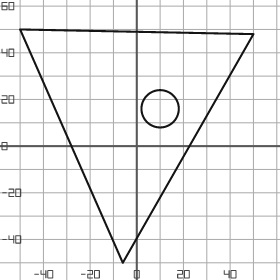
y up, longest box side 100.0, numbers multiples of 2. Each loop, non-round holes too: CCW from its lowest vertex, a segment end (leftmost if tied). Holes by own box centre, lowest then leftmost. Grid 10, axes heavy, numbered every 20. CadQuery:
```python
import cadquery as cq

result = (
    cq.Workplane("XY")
    .moveTo(-6.0, -50.0)
    .lineTo(50.0, 48.0)
    .lineTo(-50.0, 50.0)
    .close()
    .moveTo(10.0, 16.0)
    .circle(8.0)
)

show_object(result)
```